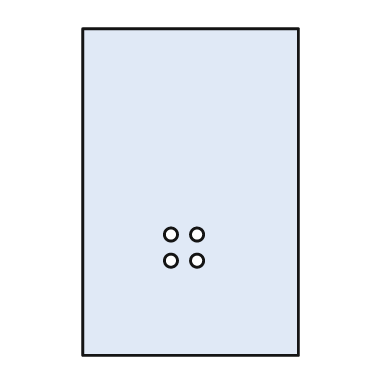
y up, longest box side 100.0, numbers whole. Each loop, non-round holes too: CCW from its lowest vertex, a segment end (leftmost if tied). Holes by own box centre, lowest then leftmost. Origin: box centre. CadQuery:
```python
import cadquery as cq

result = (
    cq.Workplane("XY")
    .moveTo(-33.0, -50.0)
    .lineTo(33.0, -50.0)
    .lineTo(33.0, 50.0)
    .lineTo(-33.0, 50.0)
    .close()
    .moveTo(-6.0, -21.0)
    .circle(2.0)
    .moveTo(2.0, -21.0)
    .circle(2.0)
    .moveTo(-6.0, -13.0)
    .circle(2.0)
    .moveTo(2.0, -13.0)
    .circle(2.0)
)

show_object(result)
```